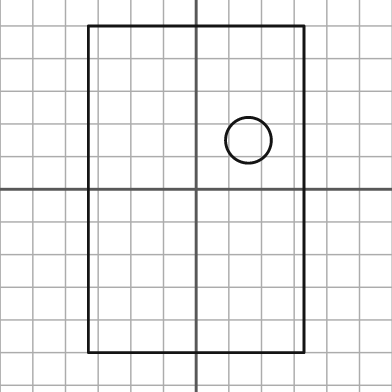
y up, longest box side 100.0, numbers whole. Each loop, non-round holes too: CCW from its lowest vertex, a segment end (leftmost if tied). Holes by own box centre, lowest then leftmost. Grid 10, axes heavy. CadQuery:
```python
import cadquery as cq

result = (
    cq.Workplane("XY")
    .moveTo(-33.0, -50.0)
    .lineTo(33.0, -50.0)
    .lineTo(33.0, 50.0)
    .lineTo(-33.0, 50.0)
    .close()
    .moveTo(16.0, 15.0)
    .circle(7.0)
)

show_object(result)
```